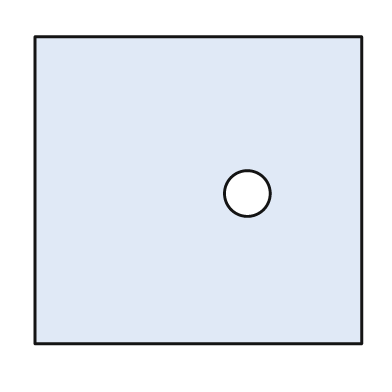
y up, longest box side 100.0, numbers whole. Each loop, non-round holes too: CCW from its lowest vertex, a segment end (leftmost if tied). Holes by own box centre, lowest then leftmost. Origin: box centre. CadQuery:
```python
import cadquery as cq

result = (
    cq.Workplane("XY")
    .moveTo(-50.0, -47.0)
    .lineTo(50.0, -47.0)
    .lineTo(50.0, 47.0)
    .lineTo(-50.0, 47.0)
    .close()
    .moveTo(15.0, -1.0)
    .circle(7.0)
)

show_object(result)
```